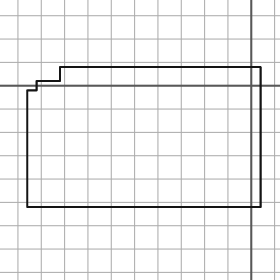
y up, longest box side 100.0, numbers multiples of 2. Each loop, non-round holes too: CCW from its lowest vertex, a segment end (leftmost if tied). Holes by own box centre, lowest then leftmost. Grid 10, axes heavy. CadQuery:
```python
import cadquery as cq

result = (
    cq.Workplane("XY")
    .moveTo(-96.0, -52.0)
    .lineTo(4.0, -52.0)
    .lineTo(4.0, 8.0)
    .lineTo(-82.0, 8.0)
    .lineTo(-82.0, 2.0)
    .lineTo(-92.0, 2.0)
    .lineTo(-92.0, -2.0)
    .lineTo(-96.0, -2.0)
    .close()
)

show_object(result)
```